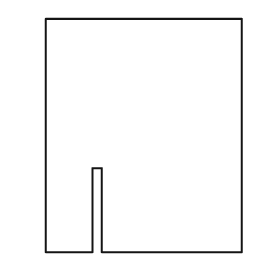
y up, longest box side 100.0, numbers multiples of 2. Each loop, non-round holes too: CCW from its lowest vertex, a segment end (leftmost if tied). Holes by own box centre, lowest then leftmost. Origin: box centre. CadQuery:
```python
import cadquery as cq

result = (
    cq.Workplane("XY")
    .moveTo(-42.0, -50.0)
    .lineTo(-22.0, -50.0)
    .lineTo(-22.0, -14.0)
    .lineTo(-18.0, -14.0)
    .lineTo(-18.0, -50.0)
    .lineTo(42.0, -50.0)
    .lineTo(42.0, 50.0)
    .lineTo(-42.0, 50.0)
    .close()
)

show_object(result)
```